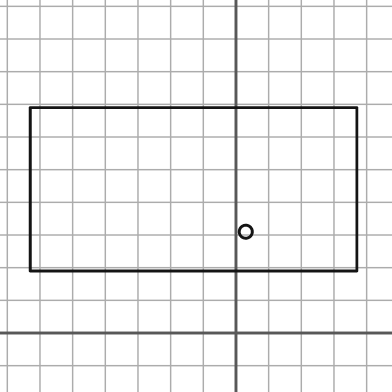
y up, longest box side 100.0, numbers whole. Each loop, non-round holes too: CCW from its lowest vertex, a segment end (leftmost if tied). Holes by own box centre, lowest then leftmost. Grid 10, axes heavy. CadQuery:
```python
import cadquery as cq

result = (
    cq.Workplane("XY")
    .moveTo(-63.0, 19.0)
    .lineTo(37.0, 19.0)
    .lineTo(37.0, 69.0)
    .lineTo(-63.0, 69.0)
    .close()
    .moveTo(3.0, 31.0)
    .circle(2.0)
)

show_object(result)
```